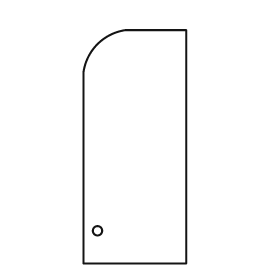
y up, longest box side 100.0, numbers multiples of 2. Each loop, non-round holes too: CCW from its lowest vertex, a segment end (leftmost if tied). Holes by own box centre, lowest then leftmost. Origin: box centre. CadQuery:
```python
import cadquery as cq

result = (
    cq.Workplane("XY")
    .moveTo(-22.0, -50.0)
    .lineTo(22.0, -50.0)
    .lineTo(22.0, 50.0)
    .lineTo(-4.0, 50.0)
    .threePointArc((-16.0, 44.0), (-22.0, 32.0))
    .close()
    .moveTo(-16.0, -36.0)
    .circle(2.0)
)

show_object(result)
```